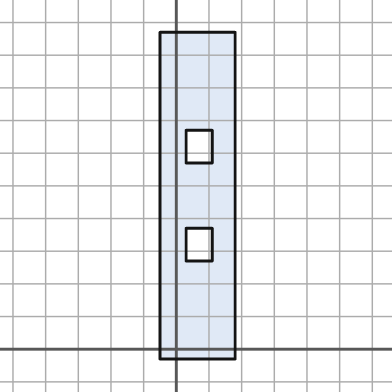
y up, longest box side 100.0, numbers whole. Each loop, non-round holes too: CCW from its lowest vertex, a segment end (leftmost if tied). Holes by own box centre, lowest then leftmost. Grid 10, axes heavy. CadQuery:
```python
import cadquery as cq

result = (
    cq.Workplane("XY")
    .moveTo(-5.0, -3.0)
    .lineTo(18.0, -3.0)
    .lineTo(18.0, 97.0)
    .lineTo(-5.0, 97.0)
    .close()
    .moveTo(3.0, 27.0)
    .lineTo(11.0, 27.0)
    .lineTo(11.0, 37.0)
    .lineTo(3.0, 37.0)
    .close()
    .moveTo(3.0, 57.0)
    .lineTo(11.0, 57.0)
    .lineTo(11.0, 67.0)
    .lineTo(3.0, 67.0)
    .close()
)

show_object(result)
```